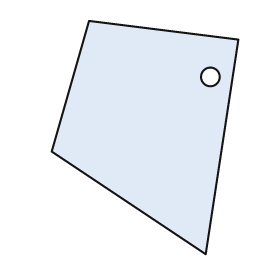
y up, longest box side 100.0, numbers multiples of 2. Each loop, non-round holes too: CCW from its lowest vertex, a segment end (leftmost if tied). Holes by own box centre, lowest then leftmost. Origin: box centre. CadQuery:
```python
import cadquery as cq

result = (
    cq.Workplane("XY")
    .moveTo(26.0, -50.0)
    .lineTo(40.0, 42.0)
    .lineTo(-24.0, 50.0)
    .lineTo(-40.0, -6.0)
    .close()
    .moveTo(28.0, 26.0)
    .circle(4.0)
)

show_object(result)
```